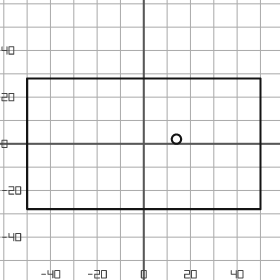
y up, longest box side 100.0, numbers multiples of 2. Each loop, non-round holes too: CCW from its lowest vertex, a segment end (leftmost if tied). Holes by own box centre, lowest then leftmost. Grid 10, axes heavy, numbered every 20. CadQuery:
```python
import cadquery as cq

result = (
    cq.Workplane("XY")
    .moveTo(-50.0, -28.0)
    .lineTo(50.0, -28.0)
    .lineTo(50.0, 28.0)
    .lineTo(-50.0, 28.0)
    .close()
    .moveTo(14.0, 2.0)
    .circle(2.0)
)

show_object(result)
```